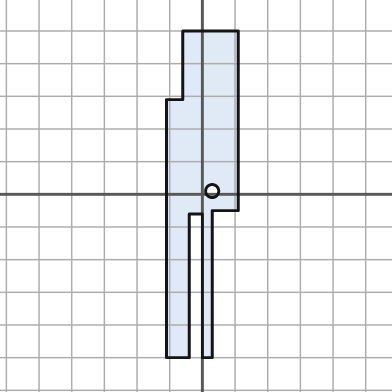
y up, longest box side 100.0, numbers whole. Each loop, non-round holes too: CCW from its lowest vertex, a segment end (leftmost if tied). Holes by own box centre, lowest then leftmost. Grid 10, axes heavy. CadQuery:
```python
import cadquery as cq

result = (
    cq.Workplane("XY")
    .moveTo(-11.0, -50.0)
    .lineTo(-4.0, -50.0)
    .lineTo(-4.0, -6.0)
    .lineTo(0.0, -6.0)
    .lineTo(0.0, -50.0)
    .lineTo(3.0, -50.0)
    .lineTo(3.0, -5.0)
    .lineTo(11.0, -5.0)
    .lineTo(11.0, 50.0)
    .lineTo(-6.0, 50.0)
    .lineTo(-6.0, 29.0)
    .lineTo(-11.0, 29.0)
    .close()
    .moveTo(3.0, 1.0)
    .circle(2.0)
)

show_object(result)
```